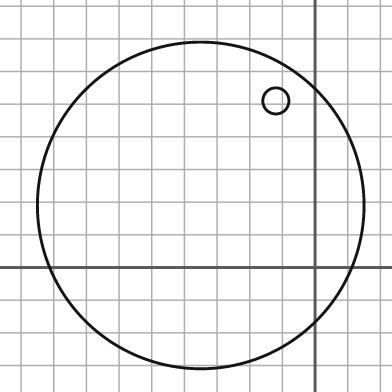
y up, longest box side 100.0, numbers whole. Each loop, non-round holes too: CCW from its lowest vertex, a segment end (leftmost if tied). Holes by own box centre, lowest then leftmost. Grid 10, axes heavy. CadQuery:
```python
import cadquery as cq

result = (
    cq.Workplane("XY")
    .moveTo(-35.0, 19.0)
    .circle(50.0)
    .moveTo(-12.0, 51.0)
    .circle(4.0)
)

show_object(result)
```